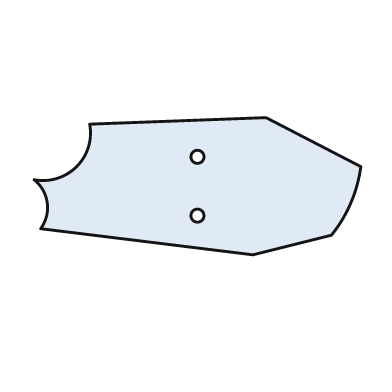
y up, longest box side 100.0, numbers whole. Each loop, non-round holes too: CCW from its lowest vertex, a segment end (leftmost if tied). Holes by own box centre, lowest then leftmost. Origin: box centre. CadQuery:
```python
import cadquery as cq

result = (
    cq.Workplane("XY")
    .moveTo(17.0, -21.0)
    .lineTo(41.0, -15.0)
    .threePointArc((47.0, -5.0), (50.0, 6.0))
    .lineTo(21.0, 21.0)
    .lineTo(-33.0, 19.0)
    .threePointArc((-37.0, 6.0), (-50.0, 2.0))
    .threePointArc((-46.0, -5.0), (-48.0, -13.0))
    .close()
    .moveTo(0.0, -9.0)
    .circle(2.0)
    .moveTo(0.0, 9.0)
    .circle(2.0)
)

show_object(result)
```